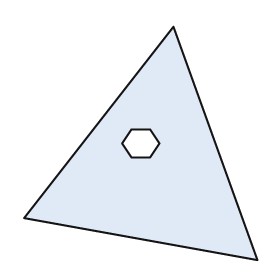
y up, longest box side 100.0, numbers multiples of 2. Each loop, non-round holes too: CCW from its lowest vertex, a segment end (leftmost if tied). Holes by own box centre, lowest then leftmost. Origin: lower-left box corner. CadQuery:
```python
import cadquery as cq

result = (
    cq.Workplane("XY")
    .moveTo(100.0, 0.0)
    .lineTo(64.0, 100.0)
    .lineTo(0.0, 18.0)
    .close()
    .moveTo(46.0, 44.0)
    .lineTo(54.0, 44.0)
    .lineTo(58.0, 50.0)
    .lineTo(54.0, 56.0)
    .lineTo(46.0, 56.0)
    .lineTo(42.0, 50.0)
    .close()
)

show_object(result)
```